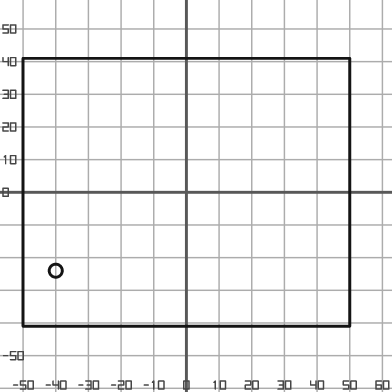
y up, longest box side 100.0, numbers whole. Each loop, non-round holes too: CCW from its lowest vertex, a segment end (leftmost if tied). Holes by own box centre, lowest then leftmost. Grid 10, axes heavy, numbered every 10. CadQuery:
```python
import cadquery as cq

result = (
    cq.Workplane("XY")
    .moveTo(-50.0, -41.0)
    .lineTo(50.0, -41.0)
    .lineTo(50.0, 41.0)
    .lineTo(-50.0, 41.0)
    .close()
    .moveTo(-40.0, -24.0)
    .circle(2.0)
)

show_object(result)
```